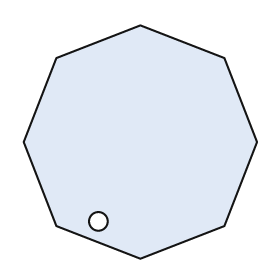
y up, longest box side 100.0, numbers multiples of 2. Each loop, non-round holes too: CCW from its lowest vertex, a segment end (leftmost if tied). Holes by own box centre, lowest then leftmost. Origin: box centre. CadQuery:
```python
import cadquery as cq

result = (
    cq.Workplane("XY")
    .moveTo(0.0, -50.0)
    .lineTo(36.0, -36.0)
    .lineTo(50.0, 0.0)
    .lineTo(36.0, 36.0)
    .lineTo(0.0, 50.0)
    .lineTo(-36.0, 36.0)
    .lineTo(-50.0, 0.0)
    .lineTo(-36.0, -36.0)
    .close()
    .moveTo(-18.0, -34.0)
    .circle(4.0)
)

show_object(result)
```